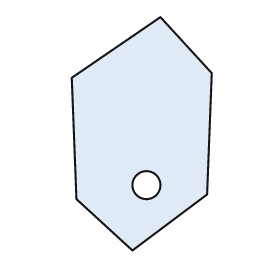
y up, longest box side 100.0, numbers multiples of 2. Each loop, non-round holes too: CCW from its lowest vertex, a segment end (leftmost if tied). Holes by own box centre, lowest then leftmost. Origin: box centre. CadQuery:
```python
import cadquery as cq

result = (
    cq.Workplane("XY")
    .moveTo(-4.0, -50.0)
    .lineTo(28.0, -26.0)
    .lineTo(30.0, 26.0)
    .lineTo(8.0, 50.0)
    .lineTo(-30.0, 24.0)
    .lineTo(-28.0, -28.0)
    .close()
    .moveTo(2.0, -22.0)
    .circle(6.0)
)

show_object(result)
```